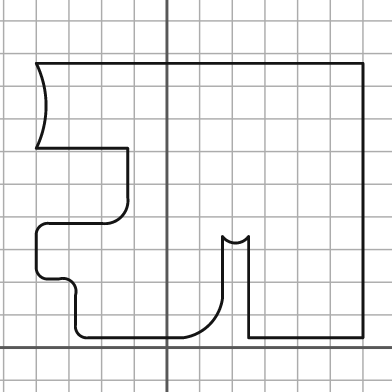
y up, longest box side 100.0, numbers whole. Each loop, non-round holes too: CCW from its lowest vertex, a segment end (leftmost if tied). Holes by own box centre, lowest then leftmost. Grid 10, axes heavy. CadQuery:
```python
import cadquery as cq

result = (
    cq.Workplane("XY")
    .moveTo(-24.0, 3.0)
    .lineTo(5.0, 3.0)
    .threePointArc((13.0, 7.0), (17.0, 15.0))
    .lineTo(17.0, 34.0)
    .threePointArc((21.0, 32.0), (25.0, 34.0))
    .lineTo(25.0, 3.0)
    .lineTo(60.0, 3.0)
    .lineTo(60.0, 87.0)
    .lineTo(-40.0, 87.0)
    .threePointArc((-37.0, 74.0), (-40.0, 61.0))
    .lineTo(-12.0, 61.0)
    .lineTo(-12.0, 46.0)
    .threePointArc((-14.0, 40.0), (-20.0, 38.0))
    .lineTo(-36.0, 38.0)
    .threePointArc((-39.0, 37.0), (-40.0, 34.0))
    .lineTo(-40.0, 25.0)
    .threePointArc((-39.0, 22.0), (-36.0, 21.0))
    .lineTo(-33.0, 21.0)
    .threePointArc((-29.0, 20.0), (-28.0, 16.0))
    .lineTo(-28.0, 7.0)
    .threePointArc((-27.0, 4.0), (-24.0, 3.0))
    .close()
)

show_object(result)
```